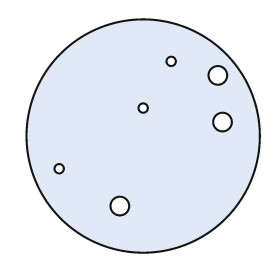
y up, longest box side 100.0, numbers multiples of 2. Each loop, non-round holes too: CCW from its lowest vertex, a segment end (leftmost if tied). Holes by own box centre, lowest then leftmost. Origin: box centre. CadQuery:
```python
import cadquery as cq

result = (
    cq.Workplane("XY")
    .moveTo(0.0, 0.0)
    .circle(50.0)
    .moveTo(-10.0, -30.0)
    .circle(4.0)
    .moveTo(-36.0, -14.0)
    .circle(2.0)
    .moveTo(34.0, 6.0)
    .circle(4.0)
    .moveTo(0.0, 12.0)
    .circle(2.0)
    .moveTo(32.0, 26.0)
    .circle(4.0)
    .moveTo(12.0, 32.0)
    .circle(2.0)
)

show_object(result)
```